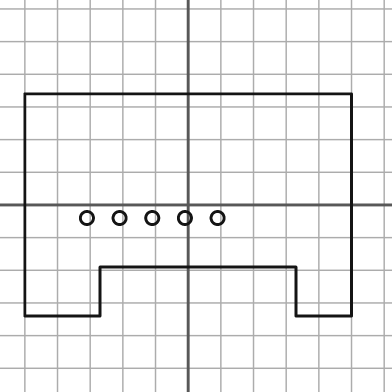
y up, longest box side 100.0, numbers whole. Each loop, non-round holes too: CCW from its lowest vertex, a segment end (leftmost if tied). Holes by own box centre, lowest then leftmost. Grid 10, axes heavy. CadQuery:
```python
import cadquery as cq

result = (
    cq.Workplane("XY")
    .moveTo(-50.0, -34.0)
    .lineTo(-27.0, -34.0)
    .lineTo(-27.0, -19.0)
    .lineTo(33.0, -19.0)
    .lineTo(33.0, -34.0)
    .lineTo(50.0, -34.0)
    .lineTo(50.0, 34.0)
    .lineTo(-50.0, 34.0)
    .close()
    .moveTo(-31.0, -4.0)
    .circle(2.0)
    .moveTo(-21.0, -4.0)
    .circle(2.0)
    .moveTo(-11.0, -4.0)
    .circle(2.0)
    .moveTo(-1.0, -4.0)
    .circle(2.0)
    .moveTo(9.0, -4.0)
    .circle(2.0)
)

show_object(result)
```